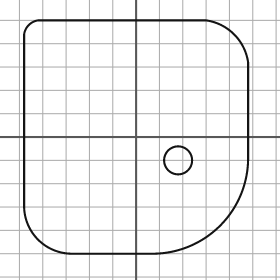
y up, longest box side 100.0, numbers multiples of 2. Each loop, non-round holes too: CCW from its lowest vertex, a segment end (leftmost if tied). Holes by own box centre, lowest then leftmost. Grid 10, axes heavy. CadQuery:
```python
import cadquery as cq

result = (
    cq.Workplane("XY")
    .moveTo(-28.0, -50.0)
    .lineTo(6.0, -50.0)
    .threePointArc((36.0, -38.0), (48.0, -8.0))
    .lineTo(48.0, 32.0)
    .threePointArc((42.0, 44.0), (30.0, 50.0))
    .lineTo(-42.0, 50.0)
    .threePointArc((-46.0, 48.0), (-48.0, 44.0))
    .lineTo(-48.0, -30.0)
    .threePointArc((-42.0, -44.0), (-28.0, -50.0))
    .close()
    .moveTo(18.0, -10.0)
    .circle(6.0)
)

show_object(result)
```